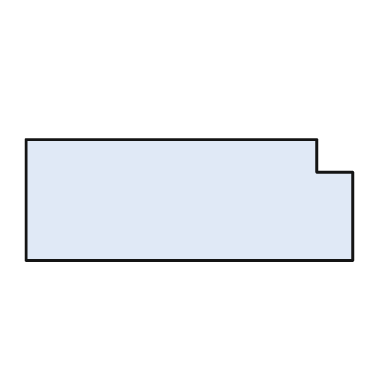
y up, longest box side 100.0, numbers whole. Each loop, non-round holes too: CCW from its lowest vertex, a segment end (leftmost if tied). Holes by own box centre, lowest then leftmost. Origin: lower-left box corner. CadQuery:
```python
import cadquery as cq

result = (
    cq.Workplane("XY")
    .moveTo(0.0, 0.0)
    .lineTo(100.0, 0.0)
    .lineTo(100.0, 27.0)
    .lineTo(89.0, 27.0)
    .lineTo(89.0, 37.0)
    .lineTo(0.0, 37.0)
    .close()
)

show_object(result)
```